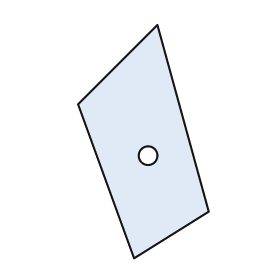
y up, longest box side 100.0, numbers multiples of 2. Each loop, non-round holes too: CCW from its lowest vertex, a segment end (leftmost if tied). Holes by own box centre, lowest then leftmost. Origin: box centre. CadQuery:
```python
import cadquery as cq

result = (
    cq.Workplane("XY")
    .moveTo(-4.0, -50.0)
    .lineTo(28.0, -30.0)
    .lineTo(6.0, 50.0)
    .lineTo(-28.0, 16.0)
    .close()
    .moveTo(2.0, -6.0)
    .circle(4.0)
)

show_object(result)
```